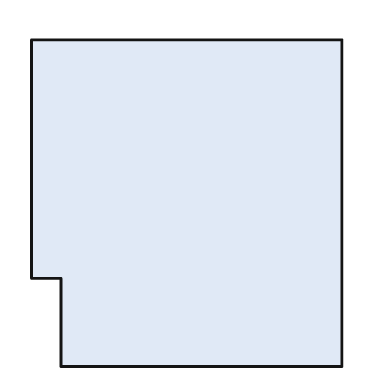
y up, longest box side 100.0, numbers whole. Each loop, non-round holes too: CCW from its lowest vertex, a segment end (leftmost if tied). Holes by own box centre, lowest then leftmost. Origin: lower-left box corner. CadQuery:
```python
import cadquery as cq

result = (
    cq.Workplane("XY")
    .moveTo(9.0, 0.0)
    .lineTo(95.0, 0.0)
    .lineTo(95.0, 100.0)
    .lineTo(0.0, 100.0)
    .lineTo(0.0, 27.0)
    .lineTo(9.0, 27.0)
    .close()
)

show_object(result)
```